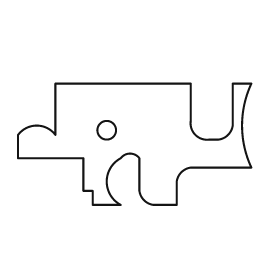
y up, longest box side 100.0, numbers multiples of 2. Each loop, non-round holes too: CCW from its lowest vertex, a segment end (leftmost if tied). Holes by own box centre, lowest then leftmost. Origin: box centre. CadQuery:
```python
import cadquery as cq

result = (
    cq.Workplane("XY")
    .moveTo(-18.0, -26.0)
    .lineTo(-6.0, -26.0)
    .threePointArc((-12.0, -16.0), (-6.0, -6.0))
    .threePointArc((-2.0, -4.0), (2.0, -6.0))
    .lineTo(2.0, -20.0)
    .threePointArc((4.0, -24.0), (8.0, -26.0))
    .lineTo(18.0, -26.0)
    .lineTo(18.0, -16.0)
    .threePointArc((20.0, -12.0), (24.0, -10.0))
    .lineTo(50.0, -10.0)
    .threePointArc((46.0, 8.0), (50.0, 26.0))
    .lineTo(42.0, 26.0)
    .lineTo(42.0, 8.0)
    .threePointArc((40.0, 4.0), (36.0, 2.0))
    .lineTo(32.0, 2.0)
    .threePointArc((26.0, 4.0), (24.0, 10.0))
    .lineTo(24.0, 26.0)
    .lineTo(-34.0, 26.0)
    .lineTo(-34.0, 4.0)
    .threePointArc((-42.0, 8.0), (-50.0, 4.0))
    .lineTo(-50.0, -6.0)
    .lineTo(-22.0, -6.0)
    .lineTo(-22.0, -20.0)
    .lineTo(-18.0, -20.0)
    .close()
    .moveTo(-12.0, 6.0)
    .circle(4.0)
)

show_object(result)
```